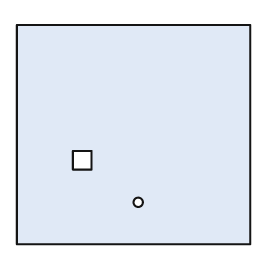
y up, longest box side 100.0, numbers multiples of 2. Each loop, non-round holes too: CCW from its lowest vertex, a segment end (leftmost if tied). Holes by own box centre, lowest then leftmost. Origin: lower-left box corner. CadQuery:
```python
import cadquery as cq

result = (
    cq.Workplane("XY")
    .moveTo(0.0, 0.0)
    .lineTo(100.0, 0.0)
    .lineTo(100.0, 94.0)
    .lineTo(0.0, 94.0)
    .close()
    .moveTo(52.0, 18.0)
    .circle(2.0)
    .moveTo(24.0, 32.0)
    .lineTo(32.0, 32.0)
    .lineTo(32.0, 40.0)
    .lineTo(24.0, 40.0)
    .close()
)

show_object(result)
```